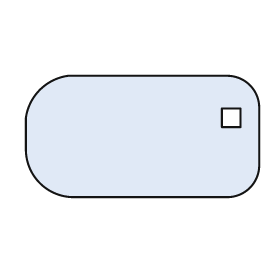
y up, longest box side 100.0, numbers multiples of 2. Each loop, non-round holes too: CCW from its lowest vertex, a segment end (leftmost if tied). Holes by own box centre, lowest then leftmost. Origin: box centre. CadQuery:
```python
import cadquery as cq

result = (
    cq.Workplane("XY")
    .moveTo(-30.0, -26.0)
    .lineTo(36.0, -26.0)
    .threePointArc((46.0, -22.0), (50.0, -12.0))
    .lineTo(50.0, 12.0)
    .threePointArc((46.0, 22.0), (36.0, 26.0))
    .lineTo(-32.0, 26.0)
    .threePointArc((-44.0, 20.0), (-50.0, 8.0))
    .lineTo(-50.0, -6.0)
    .threePointArc((-44.0, -20.0), (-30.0, -26.0))
    .close()
    .moveTo(34.0, 4.0)
    .lineTo(42.0, 4.0)
    .lineTo(42.0, 12.0)
    .lineTo(34.0, 12.0)
    .close()
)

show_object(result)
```